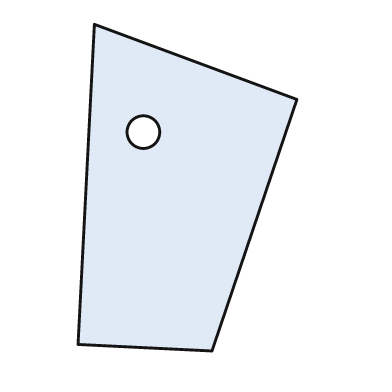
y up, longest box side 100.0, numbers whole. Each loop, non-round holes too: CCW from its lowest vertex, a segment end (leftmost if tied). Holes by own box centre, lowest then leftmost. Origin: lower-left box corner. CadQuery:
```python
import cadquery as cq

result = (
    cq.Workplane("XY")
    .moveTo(41.0, 0.0)
    .lineTo(67.0, 77.0)
    .lineTo(5.0, 100.0)
    .lineTo(0.0, 2.0)
    .close()
    .moveTo(20.0, 67.0)
    .circle(5.0)
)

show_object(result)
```